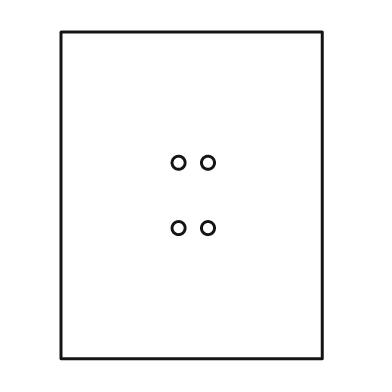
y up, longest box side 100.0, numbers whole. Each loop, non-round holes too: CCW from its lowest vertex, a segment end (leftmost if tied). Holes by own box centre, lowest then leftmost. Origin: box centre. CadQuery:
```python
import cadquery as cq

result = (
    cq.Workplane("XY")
    .moveTo(-40.0, -50.0)
    .lineTo(40.0, -50.0)
    .lineTo(40.0, 50.0)
    .lineTo(-40.0, 50.0)
    .close()
    .moveTo(-4.0, -10.0)
    .circle(2.0)
    .moveTo(5.0, -10.0)
    .circle(2.0)
    .moveTo(-4.0, 10.0)
    .circle(2.0)
    .moveTo(5.0, 10.0)
    .circle(2.0)
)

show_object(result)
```